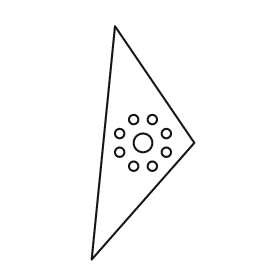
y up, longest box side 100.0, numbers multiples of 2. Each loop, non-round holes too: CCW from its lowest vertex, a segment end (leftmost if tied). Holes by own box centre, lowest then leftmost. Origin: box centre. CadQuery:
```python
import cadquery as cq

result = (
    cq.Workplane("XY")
    .moveTo(-22.0, -50.0)
    .lineTo(22.0, 0.0)
    .lineTo(-12.0, 50.0)
    .close()
    .moveTo(-4.0, -10.0)
    .circle(2.0)
    .moveTo(4.0, -10.0)
    .circle(2.0)
    .moveTo(-10.0, -4.0)
    .circle(2.0)
    .moveTo(10.0, -4.0)
    .circle(2.0)
    .moveTo(0.0, 0.0)
    .circle(4.0)
    .moveTo(-10.0, 4.0)
    .circle(2.0)
    .moveTo(10.0, 4.0)
    .circle(2.0)
    .moveTo(-4.0, 10.0)
    .circle(2.0)
    .moveTo(4.0, 10.0)
    .circle(2.0)
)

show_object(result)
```